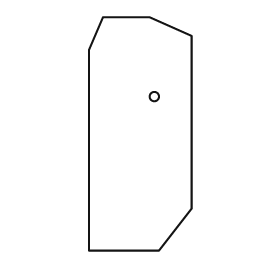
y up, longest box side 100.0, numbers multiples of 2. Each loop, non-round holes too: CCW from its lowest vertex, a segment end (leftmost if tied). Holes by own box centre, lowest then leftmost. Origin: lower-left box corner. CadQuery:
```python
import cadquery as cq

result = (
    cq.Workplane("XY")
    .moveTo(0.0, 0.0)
    .lineTo(30.0, 0.0)
    .lineTo(44.0, 18.0)
    .lineTo(44.0, 92.0)
    .lineTo(26.0, 100.0)
    .lineTo(6.0, 100.0)
    .lineTo(0.0, 86.0)
    .close()
    .moveTo(28.0, 66.0)
    .circle(2.0)
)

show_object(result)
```